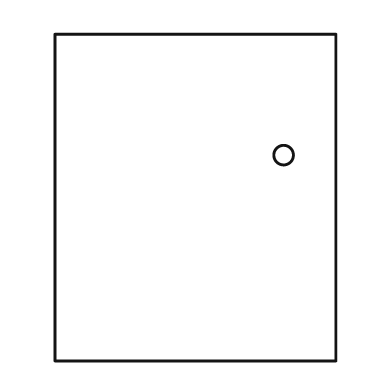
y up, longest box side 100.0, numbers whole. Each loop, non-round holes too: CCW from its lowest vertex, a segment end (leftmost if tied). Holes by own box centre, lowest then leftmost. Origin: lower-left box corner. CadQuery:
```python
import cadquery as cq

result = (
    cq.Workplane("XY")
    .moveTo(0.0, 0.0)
    .lineTo(86.0, 0.0)
    .lineTo(86.0, 100.0)
    .lineTo(0.0, 100.0)
    .close()
    .moveTo(70.0, 63.0)
    .circle(3.0)
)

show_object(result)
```